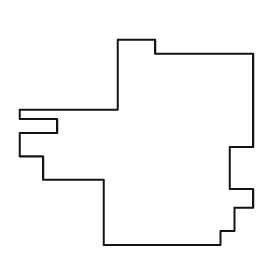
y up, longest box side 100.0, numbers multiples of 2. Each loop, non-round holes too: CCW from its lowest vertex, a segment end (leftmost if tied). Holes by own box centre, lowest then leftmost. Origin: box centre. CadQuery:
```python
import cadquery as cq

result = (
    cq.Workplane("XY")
    .moveTo(-14.0, -44.0)
    .lineTo(36.0, -44.0)
    .lineTo(36.0, -38.0)
    .lineTo(42.0, -38.0)
    .lineTo(42.0, -28.0)
    .lineTo(50.0, -28.0)
    .lineTo(50.0, -20.0)
    .lineTo(40.0, -20.0)
    .lineTo(40.0, -2.0)
    .lineTo(50.0, -2.0)
    .lineTo(50.0, 38.0)
    .lineTo(8.0, 38.0)
    .lineTo(8.0, 44.0)
    .lineTo(-8.0, 44.0)
    .lineTo(-8.0, 14.0)
    .lineTo(-50.0, 14.0)
    .lineTo(-50.0, 10.0)
    .lineTo(-34.0, 10.0)
    .lineTo(-34.0, 4.0)
    .lineTo(-50.0, 4.0)
    .lineTo(-50.0, -6.0)
    .lineTo(-40.0, -6.0)
    .lineTo(-40.0, -16.0)
    .lineTo(-14.0, -16.0)
    .close()
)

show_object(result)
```